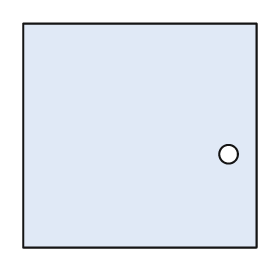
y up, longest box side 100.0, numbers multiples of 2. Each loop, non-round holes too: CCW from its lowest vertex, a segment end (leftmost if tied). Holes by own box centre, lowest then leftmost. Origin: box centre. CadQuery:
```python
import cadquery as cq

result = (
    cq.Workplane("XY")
    .moveTo(-50.0, -48.0)
    .lineTo(50.0, -48.0)
    .lineTo(50.0, 48.0)
    .lineTo(-50.0, 48.0)
    .close()
    .moveTo(38.0, -8.0)
    .circle(4.0)
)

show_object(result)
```